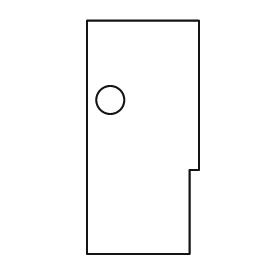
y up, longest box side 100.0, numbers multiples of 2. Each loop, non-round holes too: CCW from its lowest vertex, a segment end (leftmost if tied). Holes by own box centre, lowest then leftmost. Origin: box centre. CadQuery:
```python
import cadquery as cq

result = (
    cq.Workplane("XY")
    .moveTo(-24.0, -50.0)
    .lineTo(20.0, -50.0)
    .lineTo(20.0, -14.0)
    .lineTo(24.0, -14.0)
    .lineTo(24.0, 50.0)
    .lineTo(-24.0, 50.0)
    .close()
    .moveTo(-14.0, 16.0)
    .circle(6.0)
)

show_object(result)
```